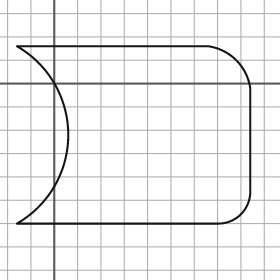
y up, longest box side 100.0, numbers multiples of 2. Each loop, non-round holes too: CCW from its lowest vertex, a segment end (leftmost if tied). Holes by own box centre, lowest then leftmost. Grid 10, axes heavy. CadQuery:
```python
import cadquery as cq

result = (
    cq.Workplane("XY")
    .moveTo(-16.0, -60.0)
    .lineTo(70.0, -60.0)
    .threePointArc((80.0, -56.0), (84.0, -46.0))
    .lineTo(84.0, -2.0)
    .threePointArc((78.0, 10.0), (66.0, 16.0))
    .lineTo(-16.0, 16.0)
    .threePointArc((6.0, -22.0), (-16.0, -60.0))
    .close()
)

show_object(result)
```